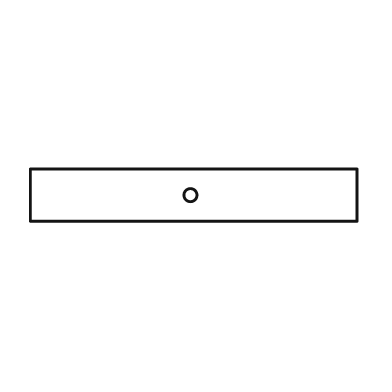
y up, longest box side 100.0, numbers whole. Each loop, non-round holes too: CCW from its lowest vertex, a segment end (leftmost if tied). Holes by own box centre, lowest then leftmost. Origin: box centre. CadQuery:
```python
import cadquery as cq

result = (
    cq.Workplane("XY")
    .moveTo(-50.0, -8.0)
    .lineTo(50.0, -8.0)
    .lineTo(50.0, 8.0)
    .lineTo(-50.0, 8.0)
    .close()
    .moveTo(-1.0, 0.0)
    .circle(2.0)
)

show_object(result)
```